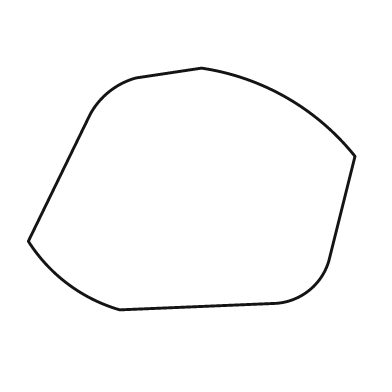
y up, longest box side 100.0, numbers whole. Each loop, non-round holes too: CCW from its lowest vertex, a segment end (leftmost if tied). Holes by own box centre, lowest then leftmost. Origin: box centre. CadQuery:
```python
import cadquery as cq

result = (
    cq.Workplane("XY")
    .moveTo(-22.0, -37.0)
    .lineTo(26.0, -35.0)
    .threePointArc((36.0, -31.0), (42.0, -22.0))
    .lineTo(50.0, 10.0)
    .threePointArc((29.0, 28.0), (3.0, 37.0))
    .lineTo(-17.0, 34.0)
    .threePointArc((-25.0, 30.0), (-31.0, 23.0))
    .lineTo(-50.0, -16.0)
    .threePointArc((-38.0, -29.0), (-22.0, -37.0))
    .close()
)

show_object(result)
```